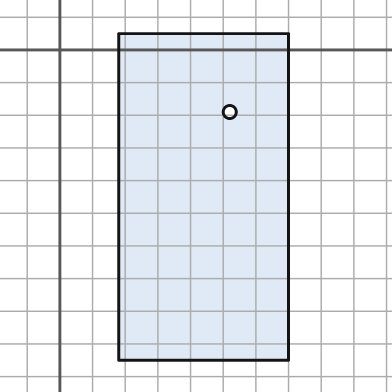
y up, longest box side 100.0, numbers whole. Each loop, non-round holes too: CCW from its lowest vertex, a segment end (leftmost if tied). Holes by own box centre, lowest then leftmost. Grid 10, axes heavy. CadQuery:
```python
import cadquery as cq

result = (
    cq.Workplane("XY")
    .moveTo(18.0, -95.0)
    .lineTo(70.0, -95.0)
    .lineTo(70.0, 5.0)
    .lineTo(18.0, 5.0)
    .close()
    .moveTo(52.0, -19.0)
    .circle(2.0)
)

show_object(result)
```